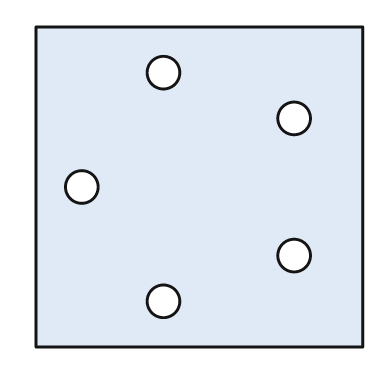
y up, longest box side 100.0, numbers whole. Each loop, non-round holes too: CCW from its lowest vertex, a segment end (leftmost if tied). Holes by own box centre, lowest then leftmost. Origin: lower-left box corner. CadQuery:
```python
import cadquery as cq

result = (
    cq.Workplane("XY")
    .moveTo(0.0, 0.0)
    .lineTo(100.0, 0.0)
    .lineTo(100.0, 98.0)
    .lineTo(0.0, 98.0)
    .close()
    .moveTo(39.0, 14.0)
    .circle(5.0)
    .moveTo(79.0, 28.0)
    .circle(5.0)
    .moveTo(14.0, 49.0)
    .circle(5.0)
    .moveTo(79.0, 70.0)
    .circle(5.0)
    .moveTo(39.0, 84.0)
    .circle(5.0)
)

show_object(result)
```